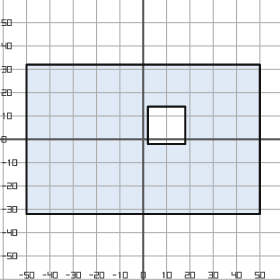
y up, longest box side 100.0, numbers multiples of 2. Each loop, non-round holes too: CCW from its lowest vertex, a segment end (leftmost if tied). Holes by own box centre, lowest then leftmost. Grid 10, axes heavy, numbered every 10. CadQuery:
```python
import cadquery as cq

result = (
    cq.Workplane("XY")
    .moveTo(-50.0, -32.0)
    .lineTo(50.0, -32.0)
    .lineTo(50.0, 32.0)
    .lineTo(-50.0, 32.0)
    .close()
    .moveTo(2.0, -2.0)
    .lineTo(18.0, -2.0)
    .lineTo(18.0, 14.0)
    .lineTo(2.0, 14.0)
    .close()
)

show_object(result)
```